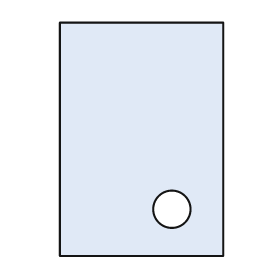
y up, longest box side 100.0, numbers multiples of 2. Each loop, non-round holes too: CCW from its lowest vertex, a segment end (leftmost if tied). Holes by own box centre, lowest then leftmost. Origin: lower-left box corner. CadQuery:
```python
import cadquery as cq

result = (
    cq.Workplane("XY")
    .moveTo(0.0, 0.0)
    .lineTo(70.0, 0.0)
    .lineTo(70.0, 100.0)
    .lineTo(0.0, 100.0)
    .close()
    .moveTo(48.0, 20.0)
    .circle(8.0)
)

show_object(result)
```